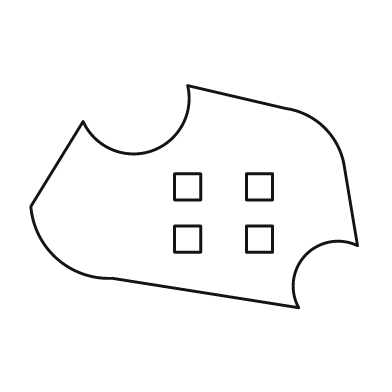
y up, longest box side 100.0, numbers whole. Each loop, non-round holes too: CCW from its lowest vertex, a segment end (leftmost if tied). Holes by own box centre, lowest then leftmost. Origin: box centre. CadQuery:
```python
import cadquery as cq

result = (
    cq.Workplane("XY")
    .moveTo(32.0, -34.0)
    .threePointArc((34.0, -18.0), (50.0, -15.0))
    .lineTo(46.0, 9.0)
    .threePointArc((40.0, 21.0), (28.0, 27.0))
    .lineTo(-2.0, 34.0)
    .threePointArc((-13.0, 14.0), (-34.0, 23.0))
    .lineTo(-50.0, -3.0)
    .threePointArc((-42.0, -19.0), (-25.0, -25.0))
    .close()
    .moveTo(-6.0, -17.0)
    .lineTo(2.0, -17.0)
    .lineTo(2.0, -9.0)
    .lineTo(-6.0, -9.0)
    .close()
    .moveTo(16.0, -17.0)
    .lineTo(24.0, -17.0)
    .lineTo(24.0, -9.0)
    .lineTo(16.0, -9.0)
    .close()
    .moveTo(-6.0, -1.0)
    .lineTo(2.0, -1.0)
    .lineTo(2.0, 7.0)
    .lineTo(-6.0, 7.0)
    .close()
    .moveTo(16.0, -1.0)
    .lineTo(24.0, -1.0)
    .lineTo(24.0, 7.0)
    .lineTo(16.0, 7.0)
    .close()
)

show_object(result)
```